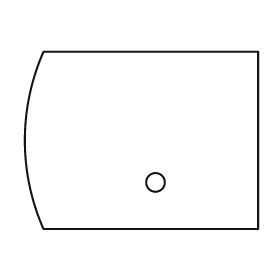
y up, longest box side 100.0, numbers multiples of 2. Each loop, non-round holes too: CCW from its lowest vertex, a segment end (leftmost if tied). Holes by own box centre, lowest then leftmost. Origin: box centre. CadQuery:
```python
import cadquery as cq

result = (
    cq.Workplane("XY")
    .moveTo(-42.0, -38.0)
    .lineTo(50.0, -38.0)
    .lineTo(50.0, 38.0)
    .lineTo(-42.0, 38.0)
    .threePointArc((-50.0, 0.0), (-42.0, -38.0))
    .close()
    .moveTo(6.0, -18.0)
    .circle(4.0)
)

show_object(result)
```